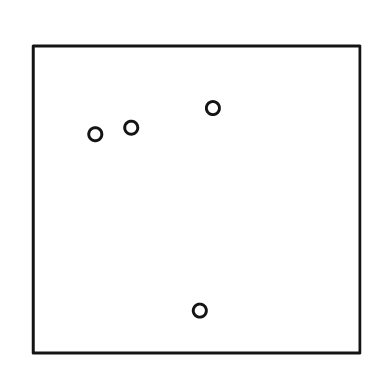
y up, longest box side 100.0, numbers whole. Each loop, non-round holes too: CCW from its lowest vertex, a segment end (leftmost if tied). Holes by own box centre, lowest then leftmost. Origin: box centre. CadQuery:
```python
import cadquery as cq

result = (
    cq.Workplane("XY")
    .moveTo(-50.0, -47.0)
    .lineTo(50.0, -47.0)
    .lineTo(50.0, 47.0)
    .lineTo(-50.0, 47.0)
    .close()
    .moveTo(1.0, -34.0)
    .circle(2.0)
    .moveTo(-31.0, 20.0)
    .circle(2.0)
    .moveTo(-20.0, 22.0)
    .circle(2.0)
    .moveTo(5.0, 28.0)
    .circle(2.0)
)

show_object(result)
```